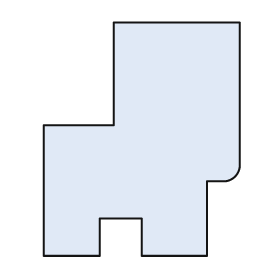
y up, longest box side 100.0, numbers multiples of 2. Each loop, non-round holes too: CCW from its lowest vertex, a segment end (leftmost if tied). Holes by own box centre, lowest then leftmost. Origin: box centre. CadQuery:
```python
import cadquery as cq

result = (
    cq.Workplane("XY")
    .moveTo(-42.0, -50.0)
    .lineTo(-18.0, -50.0)
    .lineTo(-18.0, -34.0)
    .lineTo(0.0, -34.0)
    .lineTo(0.0, -50.0)
    .lineTo(28.0, -50.0)
    .lineTo(28.0, -18.0)
    .lineTo(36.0, -18.0)
    .threePointArc((40.0, -16.0), (42.0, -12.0))
    .lineTo(42.0, 50.0)
    .lineTo(-12.0, 50.0)
    .lineTo(-12.0, 6.0)
    .lineTo(-42.0, 6.0)
    .close()
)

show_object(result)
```